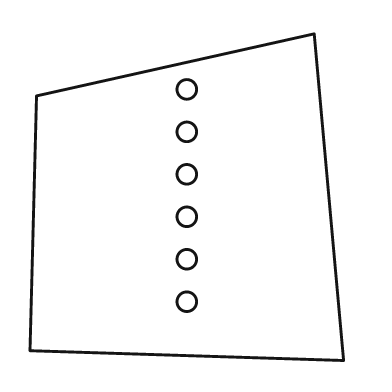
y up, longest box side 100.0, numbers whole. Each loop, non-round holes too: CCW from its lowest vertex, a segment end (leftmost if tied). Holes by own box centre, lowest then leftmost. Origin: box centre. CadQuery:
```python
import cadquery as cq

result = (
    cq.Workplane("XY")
    .moveTo(48.0, -50.0)
    .lineTo(39.0, 50.0)
    .lineTo(-46.0, 31.0)
    .lineTo(-48.0, -47.0)
    .close()
    .moveTo(0.0, -32.0)
    .circle(3.0)
    .moveTo(0.0, -19.0)
    .circle(3.0)
    .moveTo(0.0, -6.0)
    .circle(3.0)
    .moveTo(0.0, 7.0)
    .circle(3.0)
    .moveTo(0.0, 20.0)
    .circle(3.0)
    .moveTo(0.0, 33.0)
    .circle(3.0)
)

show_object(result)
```